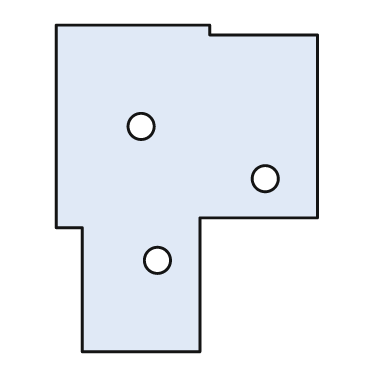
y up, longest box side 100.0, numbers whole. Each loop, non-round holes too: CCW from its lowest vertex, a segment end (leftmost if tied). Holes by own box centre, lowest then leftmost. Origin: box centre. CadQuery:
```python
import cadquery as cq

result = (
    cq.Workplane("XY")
    .moveTo(-32.0, -50.0)
    .lineTo(4.0, -50.0)
    .lineTo(4.0, -9.0)
    .lineTo(40.0, -9.0)
    .lineTo(40.0, 47.0)
    .lineTo(7.0, 47.0)
    .lineTo(7.0, 50.0)
    .lineTo(-40.0, 50.0)
    .lineTo(-40.0, -12.0)
    .lineTo(-32.0, -12.0)
    .close()
    .moveTo(-9.0, -22.0)
    .circle(4.0)
    .moveTo(24.0, 3.0)
    .circle(4.0)
    .moveTo(-14.0, 19.0)
    .circle(4.0)
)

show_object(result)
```